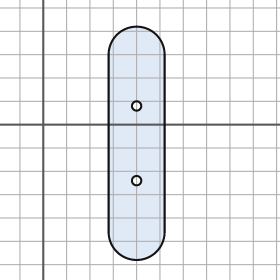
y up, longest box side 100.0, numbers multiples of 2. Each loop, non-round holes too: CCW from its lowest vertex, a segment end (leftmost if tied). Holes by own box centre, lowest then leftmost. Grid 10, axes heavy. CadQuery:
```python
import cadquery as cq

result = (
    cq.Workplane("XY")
    .moveTo(28.0, -46.0)
    .threePointArc((40.0, -58.0), (52.0, -46.0))
    .lineTo(52.0, 30.0)
    .threePointArc((40.0, 42.0), (28.0, 30.0))
    .close()
    .moveTo(40.0, -24.0)
    .circle(2.0)
    .moveTo(40.0, 8.0)
    .circle(2.0)
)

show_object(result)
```